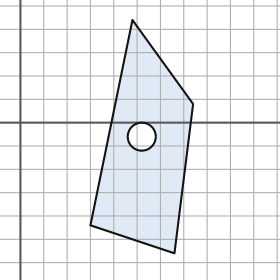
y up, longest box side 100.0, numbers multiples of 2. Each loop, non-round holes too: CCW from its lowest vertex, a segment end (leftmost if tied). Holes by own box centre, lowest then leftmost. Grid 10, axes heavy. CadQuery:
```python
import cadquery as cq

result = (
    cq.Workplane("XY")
    .moveTo(66.0, -56.0)
    .lineTo(74.0, 8.0)
    .lineTo(48.0, 44.0)
    .lineTo(30.0, -44.0)
    .close()
    .moveTo(52.0, -6.0)
    .circle(6.0)
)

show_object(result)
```